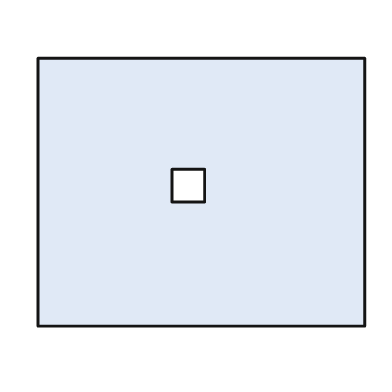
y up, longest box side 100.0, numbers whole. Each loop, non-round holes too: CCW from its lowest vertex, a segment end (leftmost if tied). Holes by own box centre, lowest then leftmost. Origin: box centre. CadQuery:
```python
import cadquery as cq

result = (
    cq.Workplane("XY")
    .moveTo(-50.0, -41.0)
    .lineTo(50.0, -41.0)
    .lineTo(50.0, 41.0)
    .lineTo(-50.0, 41.0)
    .close()
    .moveTo(-9.0, -3.0)
    .lineTo(1.0, -3.0)
    .lineTo(1.0, 7.0)
    .lineTo(-9.0, 7.0)
    .close()
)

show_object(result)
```